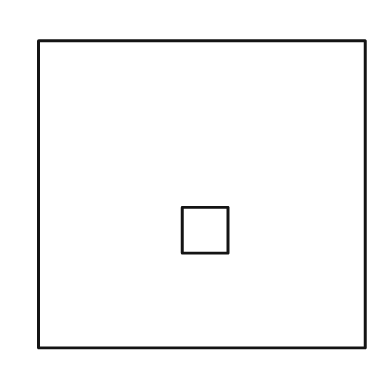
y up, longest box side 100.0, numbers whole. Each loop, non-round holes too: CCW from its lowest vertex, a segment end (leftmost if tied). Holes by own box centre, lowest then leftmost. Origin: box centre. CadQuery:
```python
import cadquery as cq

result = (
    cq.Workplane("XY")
    .moveTo(-50.0, -47.0)
    .lineTo(50.0, -47.0)
    .lineTo(50.0, 47.0)
    .lineTo(-50.0, 47.0)
    .close()
    .moveTo(-6.0, -18.0)
    .lineTo(8.0, -18.0)
    .lineTo(8.0, -4.0)
    .lineTo(-6.0, -4.0)
    .close()
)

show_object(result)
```